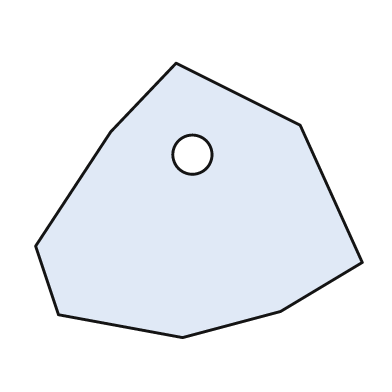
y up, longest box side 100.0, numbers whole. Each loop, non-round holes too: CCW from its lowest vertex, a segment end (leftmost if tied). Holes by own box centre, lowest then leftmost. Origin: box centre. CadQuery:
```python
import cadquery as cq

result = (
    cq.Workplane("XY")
    .moveTo(-5.0, -42.0)
    .lineTo(25.0, -34.0)
    .lineTo(50.0, -19.0)
    .lineTo(31.0, 23.0)
    .lineTo(-7.0, 42.0)
    .lineTo(-27.0, 21.0)
    .lineTo(-50.0, -14.0)
    .lineTo(-43.0, -35.0)
    .close()
    .moveTo(-2.0, 14.0)
    .circle(6.0)
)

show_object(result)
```